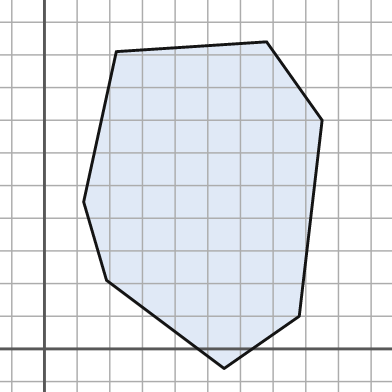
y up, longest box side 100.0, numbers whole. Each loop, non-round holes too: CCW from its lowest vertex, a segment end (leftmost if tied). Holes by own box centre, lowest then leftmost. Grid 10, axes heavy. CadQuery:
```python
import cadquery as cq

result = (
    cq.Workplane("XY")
    .moveTo(55.0, -6.0)
    .lineTo(78.0, 10.0)
    .lineTo(85.0, 70.0)
    .lineTo(68.0, 94.0)
    .lineTo(22.0, 91.0)
    .lineTo(12.0, 45.0)
    .lineTo(19.0, 21.0)
    .close()
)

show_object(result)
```